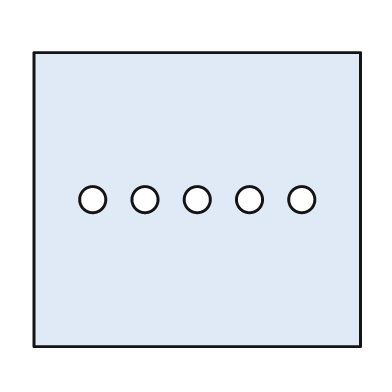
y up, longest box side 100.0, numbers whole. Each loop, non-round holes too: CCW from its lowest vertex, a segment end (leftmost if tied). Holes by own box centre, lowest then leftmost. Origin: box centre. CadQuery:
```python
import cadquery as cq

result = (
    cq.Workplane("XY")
    .moveTo(-50.0, -45.0)
    .lineTo(50.0, -45.0)
    .lineTo(50.0, 45.0)
    .lineTo(-50.0, 45.0)
    .close()
    .moveTo(-32.0, 0.0)
    .circle(4.0)
    .moveTo(-16.0, 0.0)
    .circle(4.0)
    .moveTo(0.0, 0.0)
    .circle(4.0)
    .moveTo(16.0, 0.0)
    .circle(4.0)
    .moveTo(32.0, 0.0)
    .circle(4.0)
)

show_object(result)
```